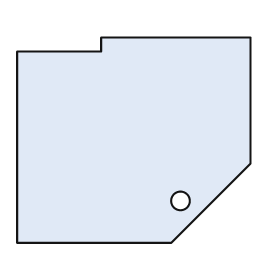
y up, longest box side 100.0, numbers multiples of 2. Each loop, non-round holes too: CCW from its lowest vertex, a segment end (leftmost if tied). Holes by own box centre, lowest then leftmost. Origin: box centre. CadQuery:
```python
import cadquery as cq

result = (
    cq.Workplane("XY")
    .moveTo(-50.0, -44.0)
    .lineTo(16.0, -44.0)
    .lineTo(50.0, -10.0)
    .lineTo(50.0, 44.0)
    .lineTo(-14.0, 44.0)
    .lineTo(-14.0, 38.0)
    .lineTo(-50.0, 38.0)
    .close()
    .moveTo(20.0, -26.0)
    .circle(4.0)
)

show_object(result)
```